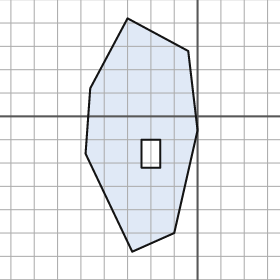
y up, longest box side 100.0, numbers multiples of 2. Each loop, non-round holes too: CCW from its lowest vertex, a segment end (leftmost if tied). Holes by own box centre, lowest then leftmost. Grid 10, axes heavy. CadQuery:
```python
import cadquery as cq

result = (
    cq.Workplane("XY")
    .moveTo(-28.0, -58.0)
    .lineTo(-10.0, -50.0)
    .lineTo(0.0, -6.0)
    .lineTo(-4.0, 28.0)
    .lineTo(-30.0, 42.0)
    .lineTo(-46.0, 12.0)
    .lineTo(-48.0, -16.0)
    .close()
    .moveTo(-24.0, -22.0)
    .lineTo(-16.0, -22.0)
    .lineTo(-16.0, -10.0)
    .lineTo(-24.0, -10.0)
    .close()
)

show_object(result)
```